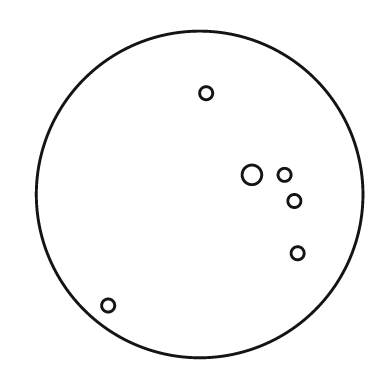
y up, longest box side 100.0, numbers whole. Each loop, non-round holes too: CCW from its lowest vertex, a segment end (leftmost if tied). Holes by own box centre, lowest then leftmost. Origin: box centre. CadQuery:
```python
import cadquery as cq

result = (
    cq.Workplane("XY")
    .moveTo(0.0, 0.0)
    .circle(50.0)
    .moveTo(-28.0, -34.0)
    .circle(2.0)
    .moveTo(30.0, -18.0)
    .circle(2.0)
    .moveTo(29.0, -2.0)
    .circle(2.0)
    .moveTo(16.0, 6.0)
    .circle(3.0)
    .moveTo(26.0, 6.0)
    .circle(2.0)
    .moveTo(2.0, 31.0)
    .circle(2.0)
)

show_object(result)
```